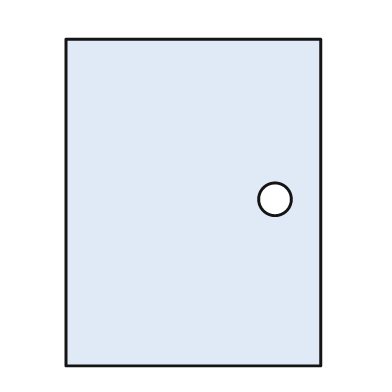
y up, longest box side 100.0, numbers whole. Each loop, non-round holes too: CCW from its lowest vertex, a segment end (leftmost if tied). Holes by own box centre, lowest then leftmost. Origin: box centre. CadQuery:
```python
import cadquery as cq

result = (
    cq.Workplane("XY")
    .moveTo(-39.0, -50.0)
    .lineTo(39.0, -50.0)
    .lineTo(39.0, 50.0)
    .lineTo(-39.0, 50.0)
    .close()
    .moveTo(25.0, 1.0)
    .circle(5.0)
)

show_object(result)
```